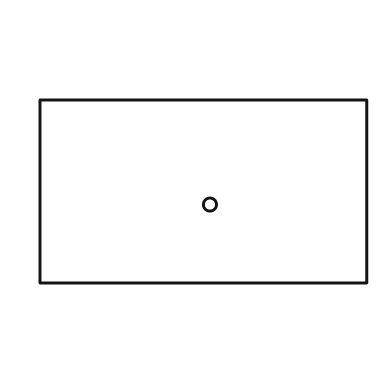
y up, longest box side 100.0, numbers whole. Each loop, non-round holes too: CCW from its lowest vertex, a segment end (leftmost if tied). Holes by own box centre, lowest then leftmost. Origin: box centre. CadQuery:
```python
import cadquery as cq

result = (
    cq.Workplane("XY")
    .moveTo(-50.0, -28.0)
    .lineTo(50.0, -28.0)
    .lineTo(50.0, 28.0)
    .lineTo(-50.0, 28.0)
    .close()
    .moveTo(2.0, -4.0)
    .circle(2.0)
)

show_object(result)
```